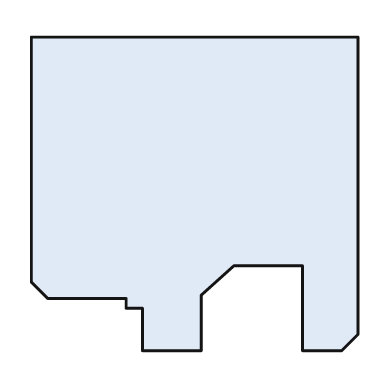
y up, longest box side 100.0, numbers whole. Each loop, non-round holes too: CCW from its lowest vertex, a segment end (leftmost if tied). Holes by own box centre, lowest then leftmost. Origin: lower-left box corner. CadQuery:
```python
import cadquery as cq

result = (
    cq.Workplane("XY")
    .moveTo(34.0, 0.0)
    .lineTo(52.0, 0.0)
    .lineTo(52.0, 17.0)
    .lineTo(62.0, 26.0)
    .lineTo(83.0, 26.0)
    .lineTo(83.0, 0.0)
    .lineTo(95.0, 0.0)
    .lineTo(100.0, 5.0)
    .lineTo(100.0, 96.0)
    .lineTo(0.0, 96.0)
    .lineTo(0.0, 21.0)
    .lineTo(5.0, 16.0)
    .lineTo(29.0, 16.0)
    .lineTo(29.0, 13.0)
    .lineTo(34.0, 13.0)
    .close()
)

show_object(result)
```